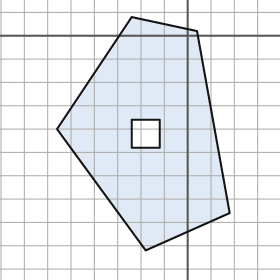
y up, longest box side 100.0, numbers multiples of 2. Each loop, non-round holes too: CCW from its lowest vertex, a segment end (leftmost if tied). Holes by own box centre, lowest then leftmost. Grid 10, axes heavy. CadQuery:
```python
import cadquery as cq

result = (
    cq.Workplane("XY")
    .moveTo(-18.0, -92.0)
    .lineTo(18.0, -76.0)
    .lineTo(4.0, 2.0)
    .lineTo(-24.0, 8.0)
    .lineTo(-56.0, -40.0)
    .close()
    .moveTo(-24.0, -48.0)
    .lineTo(-12.0, -48.0)
    .lineTo(-12.0, -36.0)
    .lineTo(-24.0, -36.0)
    .close()
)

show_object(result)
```